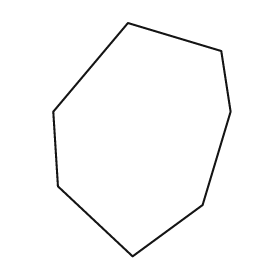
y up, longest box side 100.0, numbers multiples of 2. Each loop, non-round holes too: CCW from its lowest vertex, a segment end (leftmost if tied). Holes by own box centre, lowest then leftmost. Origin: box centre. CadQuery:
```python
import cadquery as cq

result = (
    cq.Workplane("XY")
    .moveTo(-4.0, -50.0)
    .lineTo(26.0, -28.0)
    .lineTo(38.0, 12.0)
    .lineTo(34.0, 38.0)
    .lineTo(-6.0, 50.0)
    .lineTo(-38.0, 12.0)
    .lineTo(-36.0, -20.0)
    .close()
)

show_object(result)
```